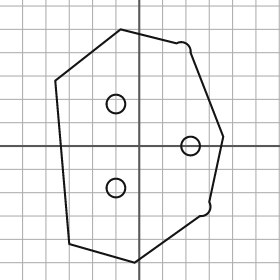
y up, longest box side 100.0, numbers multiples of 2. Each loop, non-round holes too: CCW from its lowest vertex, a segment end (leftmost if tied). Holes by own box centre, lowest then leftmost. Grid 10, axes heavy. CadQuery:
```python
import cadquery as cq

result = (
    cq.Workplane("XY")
    .moveTo(-2.0, -50.0)
    .lineTo(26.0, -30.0)
    .threePointArc((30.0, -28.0), (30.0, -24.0))
    .lineTo(36.0, 4.0)
    .lineTo(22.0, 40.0)
    .threePointArc((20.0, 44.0), (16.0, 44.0))
    .lineTo(-8.0, 50.0)
    .lineTo(-36.0, 28.0)
    .lineTo(-30.0, -42.0)
    .close()
    .moveTo(-10.0, -18.0)
    .circle(4.0)
    .moveTo(22.0, 0.0)
    .circle(4.0)
    .moveTo(-10.0, 18.0)
    .circle(4.0)
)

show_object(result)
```